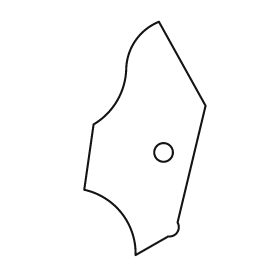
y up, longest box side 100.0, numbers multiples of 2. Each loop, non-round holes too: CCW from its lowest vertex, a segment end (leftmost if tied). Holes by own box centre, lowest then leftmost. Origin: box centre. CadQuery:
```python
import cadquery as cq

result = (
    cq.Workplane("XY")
    .moveTo(-4.0, -50.0)
    .lineTo(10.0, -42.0)
    .threePointArc((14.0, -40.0), (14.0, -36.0))
    .lineTo(26.0, 14.0)
    .lineTo(6.0, 50.0)
    .threePointArc((-4.0, 42.0), (-8.0, 30.0))
    .threePointArc((-12.0, 16.0), (-22.0, 6.0))
    .lineTo(-26.0, -22.0)
    .threePointArc((-10.0, -32.0), (-4.0, -50.0))
    .close()
    .moveTo(8.0, -6.0)
    .circle(4.0)
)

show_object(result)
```